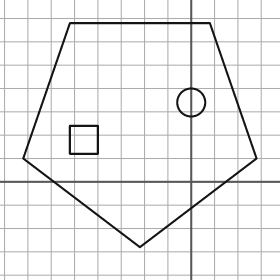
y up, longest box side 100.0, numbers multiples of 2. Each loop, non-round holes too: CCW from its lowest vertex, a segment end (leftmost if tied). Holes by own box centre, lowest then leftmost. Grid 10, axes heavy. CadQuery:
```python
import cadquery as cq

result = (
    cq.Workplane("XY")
    .moveTo(-22.0, -28.0)
    .lineTo(28.0, 10.0)
    .lineTo(8.0, 68.0)
    .lineTo(-52.0, 68.0)
    .lineTo(-72.0, 10.0)
    .close()
    .moveTo(-52.0, 12.0)
    .lineTo(-40.0, 12.0)
    .lineTo(-40.0, 24.0)
    .lineTo(-52.0, 24.0)
    .close()
    .moveTo(0.0, 34.0)
    .circle(6.0)
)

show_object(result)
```